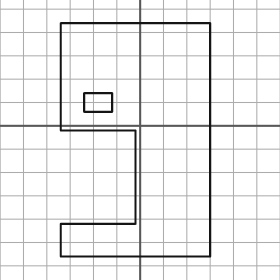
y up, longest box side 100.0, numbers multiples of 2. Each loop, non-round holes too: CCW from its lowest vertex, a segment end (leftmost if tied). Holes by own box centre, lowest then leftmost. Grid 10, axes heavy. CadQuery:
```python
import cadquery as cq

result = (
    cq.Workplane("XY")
    .moveTo(-34.0, -56.0)
    .lineTo(30.0, -56.0)
    .lineTo(30.0, 44.0)
    .lineTo(-34.0, 44.0)
    .lineTo(-34.0, -2.0)
    .lineTo(-2.0, -2.0)
    .lineTo(-2.0, -42.0)
    .lineTo(-34.0, -42.0)
    .close()
    .moveTo(-24.0, 6.0)
    .lineTo(-12.0, 6.0)
    .lineTo(-12.0, 14.0)
    .lineTo(-24.0, 14.0)
    .close()
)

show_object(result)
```